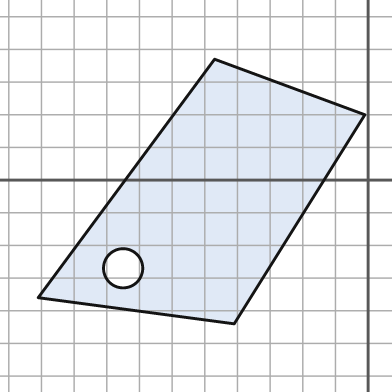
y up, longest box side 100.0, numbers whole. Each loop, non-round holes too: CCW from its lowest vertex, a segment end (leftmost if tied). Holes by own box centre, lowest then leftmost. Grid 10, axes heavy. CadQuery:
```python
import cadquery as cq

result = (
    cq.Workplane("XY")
    .moveTo(-41.0, -44.0)
    .lineTo(-1.0, 20.0)
    .lineTo(-47.0, 37.0)
    .lineTo(-101.0, -36.0)
    .close()
    .moveTo(-75.0, -27.0)
    .circle(6.0)
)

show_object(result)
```